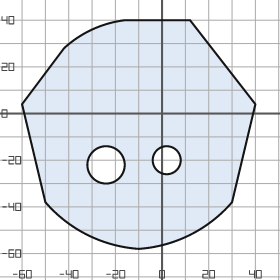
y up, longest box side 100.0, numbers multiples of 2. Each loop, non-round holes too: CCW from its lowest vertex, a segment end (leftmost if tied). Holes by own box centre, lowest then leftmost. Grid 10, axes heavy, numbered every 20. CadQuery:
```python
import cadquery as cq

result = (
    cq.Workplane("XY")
    .moveTo(-10.0, -58.0)
    .threePointArc((12.0, -52.0), (30.0, -38.0))
    .lineTo(40.0, 4.0)
    .lineTo(12.0, 40.0)
    .lineTo(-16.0, 40.0)
    .threePointArc((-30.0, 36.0), (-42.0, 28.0))
    .lineTo(-60.0, 4.0)
    .lineTo(-50.0, -38.0)
    .threePointArc((-32.0, -52.0), (-10.0, -58.0))
    .close()
    .moveTo(-24.0, -22.0)
    .circle(8.0)
    .moveTo(2.0, -20.0)
    .circle(6.0)
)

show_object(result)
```